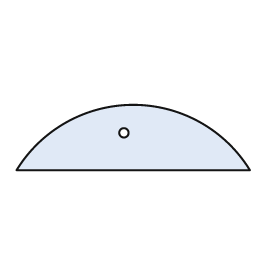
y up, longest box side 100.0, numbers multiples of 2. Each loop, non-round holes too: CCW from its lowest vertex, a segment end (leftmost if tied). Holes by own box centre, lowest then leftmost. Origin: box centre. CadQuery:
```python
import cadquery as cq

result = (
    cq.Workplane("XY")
    .moveTo(-50.0, -14.0)
    .lineTo(50.0, -14.0)
    .threePointArc((0.0, 14.0), (-50.0, -14.0))
    .close()
    .moveTo(-4.0, 2.0)
    .circle(2.0)
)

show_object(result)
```